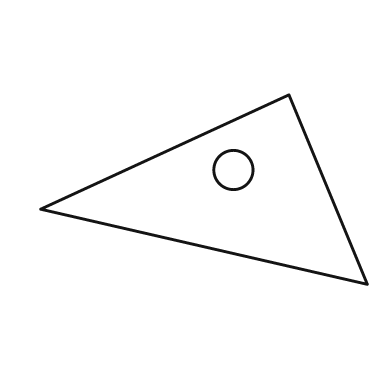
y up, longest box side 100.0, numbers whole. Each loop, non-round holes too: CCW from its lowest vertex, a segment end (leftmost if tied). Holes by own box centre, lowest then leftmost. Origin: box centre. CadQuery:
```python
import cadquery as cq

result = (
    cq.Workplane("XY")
    .moveTo(50.0, -29.0)
    .lineTo(26.0, 29.0)
    .lineTo(-50.0, -6.0)
    .close()
    .moveTo(9.0, 6.0)
    .circle(6.0)
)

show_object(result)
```